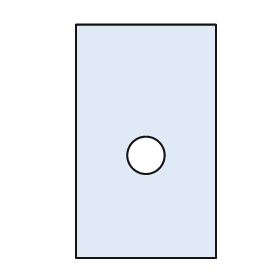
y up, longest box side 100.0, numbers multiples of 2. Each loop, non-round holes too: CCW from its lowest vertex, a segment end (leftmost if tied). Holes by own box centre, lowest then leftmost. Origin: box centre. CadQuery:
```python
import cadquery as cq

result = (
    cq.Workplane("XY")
    .moveTo(-30.0, -50.0)
    .lineTo(30.0, -50.0)
    .lineTo(30.0, 50.0)
    .lineTo(-30.0, 50.0)
    .close()
    .moveTo(0.0, -6.0)
    .circle(8.0)
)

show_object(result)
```